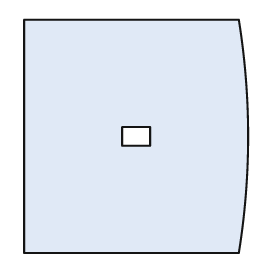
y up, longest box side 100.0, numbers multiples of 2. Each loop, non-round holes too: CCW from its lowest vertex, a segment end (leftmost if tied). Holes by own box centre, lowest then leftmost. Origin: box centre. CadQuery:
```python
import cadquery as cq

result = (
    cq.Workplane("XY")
    .moveTo(-48.0, -50.0)
    .lineTo(44.0, -50.0)
    .threePointArc((48.0, 0.0), (44.0, 50.0))
    .lineTo(-48.0, 50.0)
    .close()
    .moveTo(-6.0, -4.0)
    .lineTo(6.0, -4.0)
    .lineTo(6.0, 4.0)
    .lineTo(-6.0, 4.0)
    .close()
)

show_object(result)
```